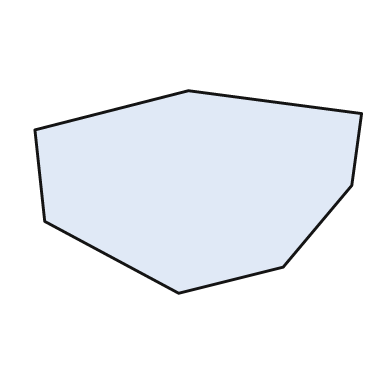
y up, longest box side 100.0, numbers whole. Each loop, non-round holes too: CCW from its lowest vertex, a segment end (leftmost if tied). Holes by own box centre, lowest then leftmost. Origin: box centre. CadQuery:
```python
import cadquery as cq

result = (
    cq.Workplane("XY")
    .moveTo(-6.0, -31.0)
    .lineTo(26.0, -23.0)
    .lineTo(47.0, 2.0)
    .lineTo(50.0, 24.0)
    .lineTo(-3.0, 31.0)
    .lineTo(-50.0, 19.0)
    .lineTo(-47.0, -9.0)
    .close()
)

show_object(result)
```